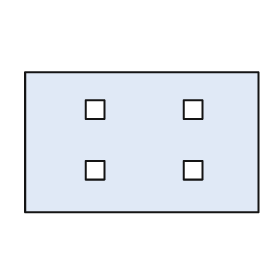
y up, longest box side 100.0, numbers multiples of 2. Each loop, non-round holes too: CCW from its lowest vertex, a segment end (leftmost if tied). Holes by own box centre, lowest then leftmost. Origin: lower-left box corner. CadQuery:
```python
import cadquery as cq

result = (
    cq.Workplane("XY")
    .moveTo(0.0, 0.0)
    .lineTo(100.0, 0.0)
    .lineTo(100.0, 60.0)
    .lineTo(0.0, 60.0)
    .close()
    .moveTo(26.0, 14.0)
    .lineTo(34.0, 14.0)
    .lineTo(34.0, 22.0)
    .lineTo(26.0, 22.0)
    .close()
    .moveTo(68.0, 14.0)
    .lineTo(76.0, 14.0)
    .lineTo(76.0, 22.0)
    .lineTo(68.0, 22.0)
    .close()
    .moveTo(26.0, 40.0)
    .lineTo(34.0, 40.0)
    .lineTo(34.0, 48.0)
    .lineTo(26.0, 48.0)
    .close()
    .moveTo(68.0, 40.0)
    .lineTo(76.0, 40.0)
    .lineTo(76.0, 48.0)
    .lineTo(68.0, 48.0)
    .close()
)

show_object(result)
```